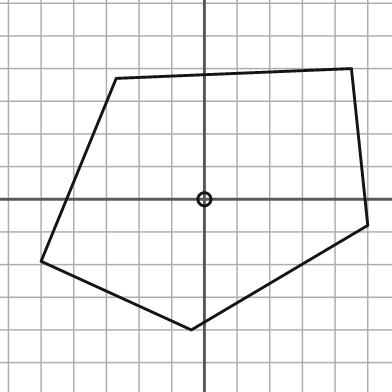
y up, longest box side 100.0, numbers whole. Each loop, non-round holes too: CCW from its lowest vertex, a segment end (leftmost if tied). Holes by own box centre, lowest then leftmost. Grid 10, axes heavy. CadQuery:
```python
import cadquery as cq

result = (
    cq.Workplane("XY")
    .moveTo(-4.0, -40.0)
    .lineTo(50.0, -8.0)
    .lineTo(45.0, 40.0)
    .lineTo(-27.0, 37.0)
    .lineTo(-50.0, -19.0)
    .close()
    .moveTo(0.0, 0.0)
    .circle(2.0)
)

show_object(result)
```